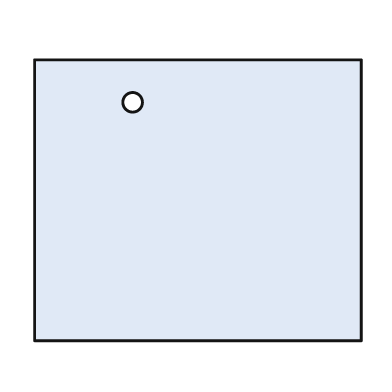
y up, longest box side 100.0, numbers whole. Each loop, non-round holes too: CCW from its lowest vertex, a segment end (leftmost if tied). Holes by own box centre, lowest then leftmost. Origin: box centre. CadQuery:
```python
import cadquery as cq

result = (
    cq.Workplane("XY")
    .moveTo(-50.0, -43.0)
    .lineTo(50.0, -43.0)
    .lineTo(50.0, 43.0)
    .lineTo(-50.0, 43.0)
    .close()
    .moveTo(-20.0, 30.0)
    .circle(3.0)
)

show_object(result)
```